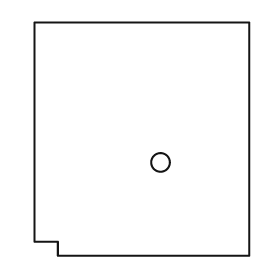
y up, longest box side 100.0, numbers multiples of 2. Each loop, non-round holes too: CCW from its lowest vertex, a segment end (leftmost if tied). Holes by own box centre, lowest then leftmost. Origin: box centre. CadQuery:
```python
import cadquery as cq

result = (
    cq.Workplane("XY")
    .moveTo(-36.0, -50.0)
    .lineTo(46.0, -50.0)
    .lineTo(46.0, 50.0)
    .lineTo(-46.0, 50.0)
    .lineTo(-46.0, -44.0)
    .lineTo(-36.0, -44.0)
    .close()
    .moveTo(8.0, -10.0)
    .circle(4.0)
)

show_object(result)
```